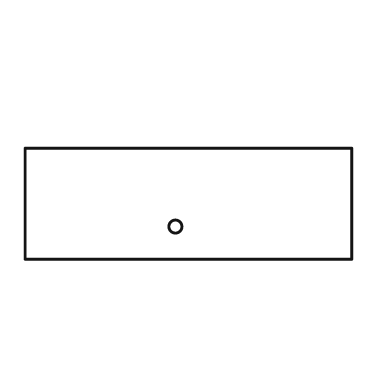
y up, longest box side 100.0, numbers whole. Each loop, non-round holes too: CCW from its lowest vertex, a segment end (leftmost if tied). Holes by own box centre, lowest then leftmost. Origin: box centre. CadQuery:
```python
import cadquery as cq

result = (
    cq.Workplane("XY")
    .moveTo(-50.0, -17.0)
    .lineTo(50.0, -17.0)
    .lineTo(50.0, 17.0)
    .lineTo(-50.0, 17.0)
    .close()
    .moveTo(-4.0, -7.0)
    .circle(2.0)
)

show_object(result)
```